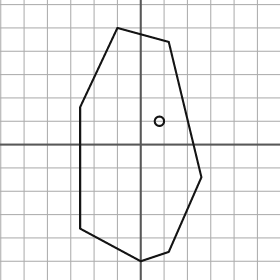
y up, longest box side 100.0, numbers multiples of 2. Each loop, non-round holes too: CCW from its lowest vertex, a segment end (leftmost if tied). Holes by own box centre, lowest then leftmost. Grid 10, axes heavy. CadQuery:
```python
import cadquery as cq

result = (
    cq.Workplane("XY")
    .moveTo(0.0, -50.0)
    .lineTo(12.0, -46.0)
    .lineTo(26.0, -14.0)
    .lineTo(12.0, 44.0)
    .lineTo(-10.0, 50.0)
    .lineTo(-26.0, 16.0)
    .lineTo(-26.0, -36.0)
    .close()
    .moveTo(8.0, 10.0)
    .circle(2.0)
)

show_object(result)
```